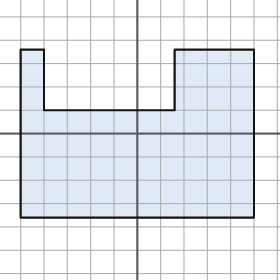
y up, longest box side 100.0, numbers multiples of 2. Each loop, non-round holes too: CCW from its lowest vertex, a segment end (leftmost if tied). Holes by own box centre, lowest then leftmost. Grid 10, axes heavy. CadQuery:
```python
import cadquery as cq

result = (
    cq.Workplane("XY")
    .moveTo(-50.0, -36.0)
    .lineTo(50.0, -36.0)
    .lineTo(50.0, 36.0)
    .lineTo(16.0, 36.0)
    .lineTo(16.0, 10.0)
    .lineTo(-40.0, 10.0)
    .lineTo(-40.0, 36.0)
    .lineTo(-50.0, 36.0)
    .close()
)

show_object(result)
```